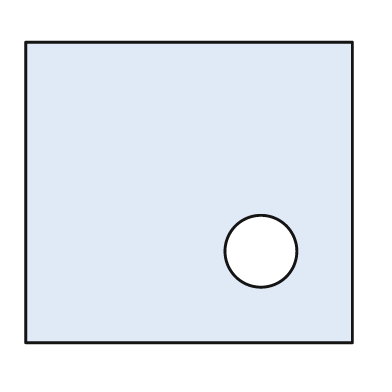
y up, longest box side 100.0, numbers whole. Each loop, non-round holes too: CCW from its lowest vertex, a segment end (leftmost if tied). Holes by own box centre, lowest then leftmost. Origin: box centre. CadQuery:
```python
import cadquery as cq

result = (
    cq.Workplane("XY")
    .moveTo(-50.0, -46.0)
    .lineTo(50.0, -46.0)
    .lineTo(50.0, 46.0)
    .lineTo(-50.0, 46.0)
    .close()
    .moveTo(22.0, -18.0)
    .circle(11.0)
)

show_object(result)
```